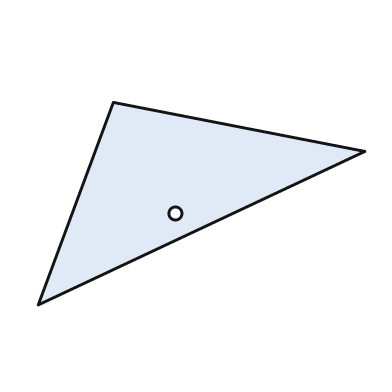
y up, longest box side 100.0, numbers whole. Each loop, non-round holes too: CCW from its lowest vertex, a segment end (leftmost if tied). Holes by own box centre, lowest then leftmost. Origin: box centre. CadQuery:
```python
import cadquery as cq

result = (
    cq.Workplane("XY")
    .moveTo(-50.0, -31.0)
    .lineTo(50.0, 16.0)
    .lineTo(-27.0, 31.0)
    .close()
    .moveTo(-8.0, -3.0)
    .circle(2.0)
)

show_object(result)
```